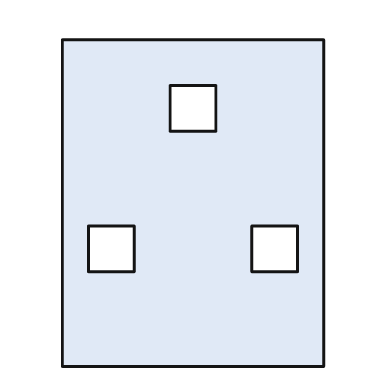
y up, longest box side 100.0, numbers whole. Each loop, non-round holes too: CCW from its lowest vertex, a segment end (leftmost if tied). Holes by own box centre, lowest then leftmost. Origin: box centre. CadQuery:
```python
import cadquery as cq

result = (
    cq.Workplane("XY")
    .moveTo(-40.0, -50.0)
    .lineTo(40.0, -50.0)
    .lineTo(40.0, 50.0)
    .lineTo(-40.0, 50.0)
    .close()
    .moveTo(-32.0, -21.0)
    .lineTo(-18.0, -21.0)
    .lineTo(-18.0, -7.0)
    .lineTo(-32.0, -7.0)
    .close()
    .moveTo(18.0, -21.0)
    .lineTo(32.0, -21.0)
    .lineTo(32.0, -7.0)
    .lineTo(18.0, -7.0)
    .close()
    .moveTo(-7.0, 22.0)
    .lineTo(7.0, 22.0)
    .lineTo(7.0, 36.0)
    .lineTo(-7.0, 36.0)
    .close()
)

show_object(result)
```